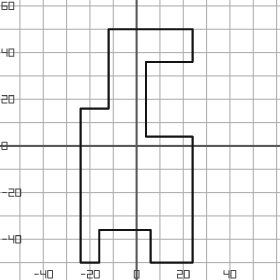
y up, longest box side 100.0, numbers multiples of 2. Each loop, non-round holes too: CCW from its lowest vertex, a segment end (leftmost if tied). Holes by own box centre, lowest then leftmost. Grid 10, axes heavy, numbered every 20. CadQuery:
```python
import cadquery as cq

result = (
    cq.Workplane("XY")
    .moveTo(-24.0, -50.0)
    .lineTo(-16.0, -50.0)
    .lineTo(-16.0, -36.0)
    .lineTo(6.0, -36.0)
    .lineTo(6.0, -50.0)
    .lineTo(24.0, -50.0)
    .lineTo(24.0, 4.0)
    .lineTo(4.0, 4.0)
    .lineTo(4.0, 36.0)
    .lineTo(24.0, 36.0)
    .lineTo(24.0, 50.0)
    .lineTo(-12.0, 50.0)
    .lineTo(-12.0, 16.0)
    .lineTo(-24.0, 16.0)
    .close()
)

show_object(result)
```